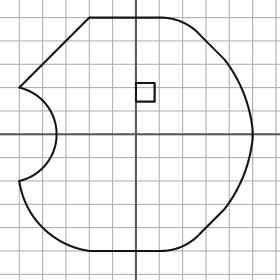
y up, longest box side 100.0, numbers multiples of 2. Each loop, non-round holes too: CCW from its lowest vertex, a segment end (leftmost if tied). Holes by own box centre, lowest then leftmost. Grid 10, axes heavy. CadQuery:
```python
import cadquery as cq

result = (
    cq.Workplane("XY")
    .moveTo(-20.0, -50.0)
    .lineTo(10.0, -50.0)
    .threePointArc((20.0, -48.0), (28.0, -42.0))
    .lineTo(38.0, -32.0)
    .threePointArc((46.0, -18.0), (50.0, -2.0))
    .lineTo(50.0, 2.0)
    .threePointArc((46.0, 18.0), (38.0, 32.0))
    .lineTo(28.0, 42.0)
    .threePointArc((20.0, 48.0), (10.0, 50.0))
    .lineTo(-20.0, 50.0)
    .lineTo(-50.0, 20.0)
    .threePointArc((-34.0, 0.0), (-50.0, -20.0))
    .threePointArc((-40.0, -40.0), (-20.0, -50.0))
    .close()
    .moveTo(0.0, 14.0)
    .lineTo(8.0, 14.0)
    .lineTo(8.0, 22.0)
    .lineTo(0.0, 22.0)
    .close()
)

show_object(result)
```